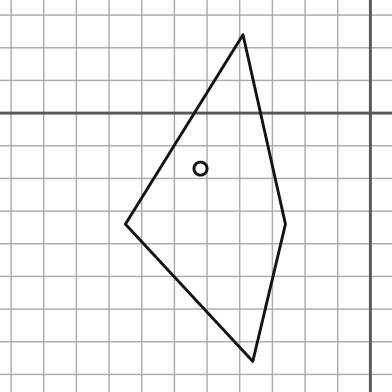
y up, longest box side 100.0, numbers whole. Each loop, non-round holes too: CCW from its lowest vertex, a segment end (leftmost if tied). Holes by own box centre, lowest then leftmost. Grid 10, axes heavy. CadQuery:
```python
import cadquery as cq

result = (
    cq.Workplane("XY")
    .moveTo(-36.0, -76.0)
    .lineTo(-26.0, -34.0)
    .lineTo(-39.0, 24.0)
    .lineTo(-75.0, -34.0)
    .close()
    .moveTo(-52.0, -17.0)
    .circle(2.0)
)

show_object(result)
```